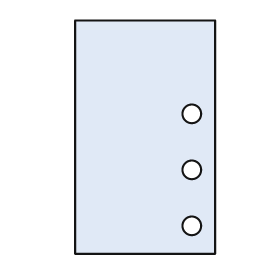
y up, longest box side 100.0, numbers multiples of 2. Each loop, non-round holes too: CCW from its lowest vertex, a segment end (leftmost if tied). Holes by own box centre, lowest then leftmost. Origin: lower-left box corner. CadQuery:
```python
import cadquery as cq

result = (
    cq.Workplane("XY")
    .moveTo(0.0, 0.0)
    .lineTo(60.0, 0.0)
    .lineTo(60.0, 100.0)
    .lineTo(0.0, 100.0)
    .close()
    .moveTo(50.0, 12.0)
    .circle(4.0)
    .moveTo(50.0, 36.0)
    .circle(4.0)
    .moveTo(50.0, 60.0)
    .circle(4.0)
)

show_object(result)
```